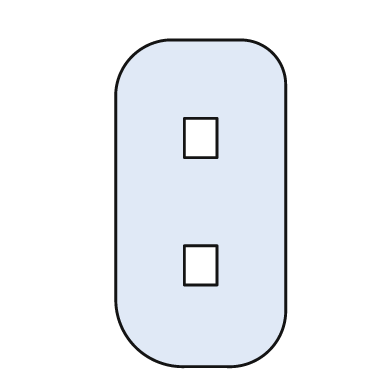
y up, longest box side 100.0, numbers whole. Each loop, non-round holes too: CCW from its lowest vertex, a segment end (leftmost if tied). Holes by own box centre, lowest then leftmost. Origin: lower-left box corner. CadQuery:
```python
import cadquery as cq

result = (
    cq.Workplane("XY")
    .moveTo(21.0, 0.0)
    .lineTo(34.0, 0.0)
    .threePointArc((47.0, 5.0), (52.0, 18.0))
    .lineTo(52.0, 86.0)
    .threePointArc((48.0, 96.0), (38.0, 100.0))
    .lineTo(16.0, 100.0)
    .threePointArc((5.0, 95.0), (0.0, 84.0))
    .lineTo(0.0, 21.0)
    .threePointArc((6.0, 6.0), (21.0, 0.0))
    .close()
    .moveTo(21.0, 25.0)
    .lineTo(31.0, 25.0)
    .lineTo(31.0, 37.0)
    .lineTo(21.0, 37.0)
    .close()
    .moveTo(21.0, 64.0)
    .lineTo(31.0, 64.0)
    .lineTo(31.0, 76.0)
    .lineTo(21.0, 76.0)
    .close()
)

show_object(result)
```